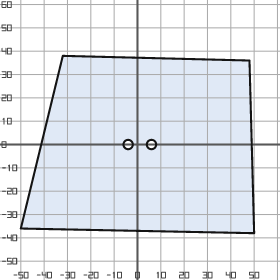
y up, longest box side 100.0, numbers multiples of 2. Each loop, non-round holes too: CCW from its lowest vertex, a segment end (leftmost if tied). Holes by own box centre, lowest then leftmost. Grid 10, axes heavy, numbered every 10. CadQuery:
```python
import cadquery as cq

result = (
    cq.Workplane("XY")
    .moveTo(50.0, -38.0)
    .lineTo(48.0, 36.0)
    .lineTo(-32.0, 38.0)
    .lineTo(-50.0, -36.0)
    .close()
    .moveTo(-4.0, 0.0)
    .circle(2.0)
    .moveTo(6.0, 0.0)
    .circle(2.0)
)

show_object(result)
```